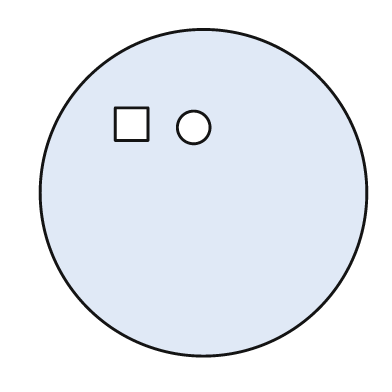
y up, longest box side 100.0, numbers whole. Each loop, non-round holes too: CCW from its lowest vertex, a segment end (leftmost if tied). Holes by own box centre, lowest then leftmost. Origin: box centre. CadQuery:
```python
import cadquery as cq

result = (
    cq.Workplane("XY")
    .moveTo(0.0, 0.0)
    .circle(50.0)
    .moveTo(-3.0, 20.0)
    .circle(5.0)
    .moveTo(-27.0, 16.0)
    .lineTo(-17.0, 16.0)
    .lineTo(-17.0, 26.0)
    .lineTo(-27.0, 26.0)
    .close()
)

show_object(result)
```